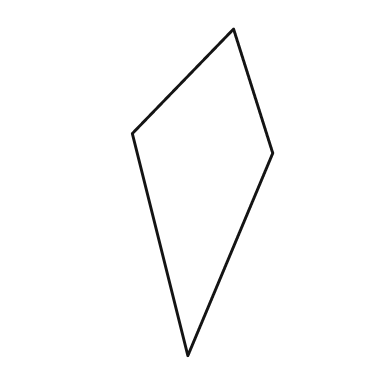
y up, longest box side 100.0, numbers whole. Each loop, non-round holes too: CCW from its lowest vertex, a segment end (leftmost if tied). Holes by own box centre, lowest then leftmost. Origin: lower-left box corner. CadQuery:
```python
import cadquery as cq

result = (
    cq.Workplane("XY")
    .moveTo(17.0, 0.0)
    .lineTo(43.0, 62.0)
    .lineTo(31.0, 100.0)
    .lineTo(0.0, 68.0)
    .close()
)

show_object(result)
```